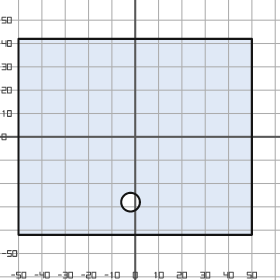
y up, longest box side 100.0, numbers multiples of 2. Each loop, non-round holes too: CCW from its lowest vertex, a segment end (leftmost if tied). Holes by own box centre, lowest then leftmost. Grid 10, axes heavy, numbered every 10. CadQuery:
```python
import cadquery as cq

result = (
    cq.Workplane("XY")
    .moveTo(-50.0, -42.0)
    .lineTo(50.0, -42.0)
    .lineTo(50.0, 42.0)
    .lineTo(-50.0, 42.0)
    .close()
    .moveTo(-2.0, -28.0)
    .circle(4.0)
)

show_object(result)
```